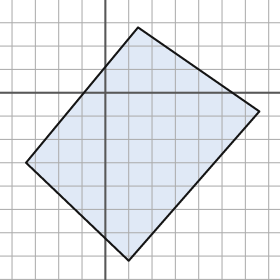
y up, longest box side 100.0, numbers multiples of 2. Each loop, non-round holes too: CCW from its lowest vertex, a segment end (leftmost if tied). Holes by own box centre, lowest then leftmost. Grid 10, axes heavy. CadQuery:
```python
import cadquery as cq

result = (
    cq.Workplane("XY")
    .moveTo(10.0, -72.0)
    .lineTo(66.0, -8.0)
    .lineTo(14.0, 28.0)
    .lineTo(-34.0, -30.0)
    .close()
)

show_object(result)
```